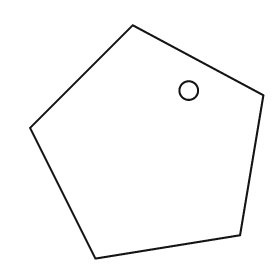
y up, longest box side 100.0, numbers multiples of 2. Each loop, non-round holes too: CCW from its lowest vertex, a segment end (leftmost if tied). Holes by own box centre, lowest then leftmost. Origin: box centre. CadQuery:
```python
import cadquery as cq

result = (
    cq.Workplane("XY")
    .moveTo(-22.0, -50.0)
    .lineTo(40.0, -40.0)
    .lineTo(50.0, 20.0)
    .lineTo(-6.0, 50.0)
    .lineTo(-50.0, 6.0)
    .close()
    .moveTo(18.0, 22.0)
    .circle(4.0)
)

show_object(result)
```